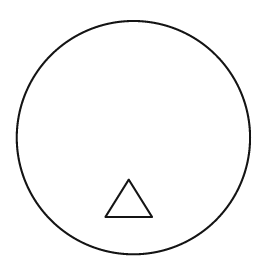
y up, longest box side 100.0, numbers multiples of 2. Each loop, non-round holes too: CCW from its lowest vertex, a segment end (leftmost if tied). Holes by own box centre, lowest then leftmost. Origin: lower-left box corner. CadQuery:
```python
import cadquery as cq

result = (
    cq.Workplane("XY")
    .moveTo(50.0, 50.0)
    .circle(50.0)
    .moveTo(38.0, 16.0)
    .lineTo(58.0, 16.0)
    .lineTo(48.0, 32.0)
    .close()
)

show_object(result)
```